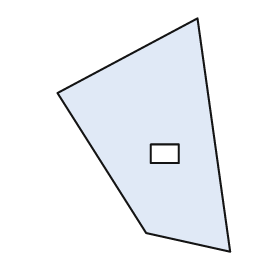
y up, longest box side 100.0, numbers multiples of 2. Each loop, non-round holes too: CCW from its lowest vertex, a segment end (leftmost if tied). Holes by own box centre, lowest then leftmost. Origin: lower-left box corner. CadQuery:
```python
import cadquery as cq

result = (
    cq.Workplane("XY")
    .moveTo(74.0, 0.0)
    .lineTo(60.0, 100.0)
    .lineTo(0.0, 68.0)
    .lineTo(38.0, 8.0)
    .close()
    .moveTo(40.0, 38.0)
    .lineTo(52.0, 38.0)
    .lineTo(52.0, 46.0)
    .lineTo(40.0, 46.0)
    .close()
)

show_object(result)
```